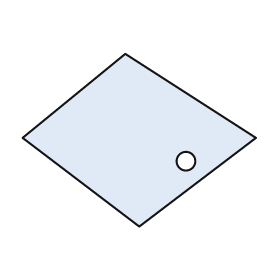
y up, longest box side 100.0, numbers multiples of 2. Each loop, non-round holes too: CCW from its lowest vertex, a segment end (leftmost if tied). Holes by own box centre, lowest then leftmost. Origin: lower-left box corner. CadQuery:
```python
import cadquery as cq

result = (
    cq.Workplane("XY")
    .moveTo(50.0, 0.0)
    .lineTo(100.0, 38.0)
    .lineTo(44.0, 74.0)
    .lineTo(0.0, 38.0)
    .close()
    .moveTo(70.0, 28.0)
    .circle(4.0)
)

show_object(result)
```